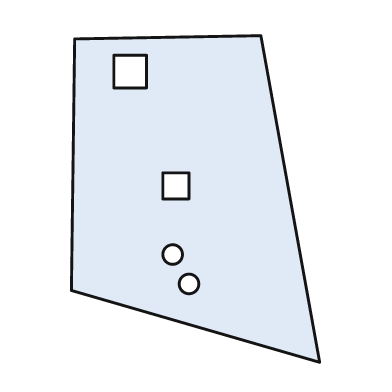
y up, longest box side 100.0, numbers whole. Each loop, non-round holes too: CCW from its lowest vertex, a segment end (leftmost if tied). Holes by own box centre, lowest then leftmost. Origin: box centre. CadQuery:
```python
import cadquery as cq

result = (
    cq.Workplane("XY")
    .moveTo(38.0, -50.0)
    .lineTo(20.0, 50.0)
    .lineTo(-37.0, 49.0)
    .lineTo(-38.0, -28.0)
    .close()
    .moveTo(-2.0, -26.0)
    .circle(3.0)
    .moveTo(-7.0, -17.0)
    .circle(3.0)
    .moveTo(-10.0, 0.0)
    .lineTo(-2.0, 0.0)
    .lineTo(-2.0, 8.0)
    .lineTo(-10.0, 8.0)
    .close()
    .moveTo(-25.0, 34.0)
    .lineTo(-15.0, 34.0)
    .lineTo(-15.0, 44.0)
    .lineTo(-25.0, 44.0)
    .close()
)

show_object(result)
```